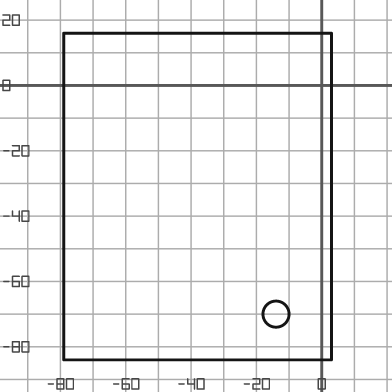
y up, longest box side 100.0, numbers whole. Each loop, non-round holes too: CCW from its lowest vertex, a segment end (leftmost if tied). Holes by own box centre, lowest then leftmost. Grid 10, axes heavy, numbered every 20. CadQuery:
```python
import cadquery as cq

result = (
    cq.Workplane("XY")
    .moveTo(-79.0, -84.0)
    .lineTo(3.0, -84.0)
    .lineTo(3.0, 16.0)
    .lineTo(-79.0, 16.0)
    .close()
    .moveTo(-14.0, -70.0)
    .circle(4.0)
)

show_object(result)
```